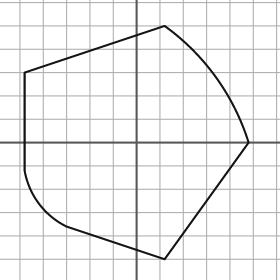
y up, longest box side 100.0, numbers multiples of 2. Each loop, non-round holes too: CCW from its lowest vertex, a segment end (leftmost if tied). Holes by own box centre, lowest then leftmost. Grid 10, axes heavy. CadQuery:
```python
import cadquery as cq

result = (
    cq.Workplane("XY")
    .moveTo(12.0, -50.0)
    .lineTo(48.0, 0.0)
    .threePointArc((34.0, 28.0), (12.0, 50.0))
    .lineTo(-48.0, 30.0)
    .lineTo(-48.0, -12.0)
    .threePointArc((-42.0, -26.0), (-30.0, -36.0))
    .close()
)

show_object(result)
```